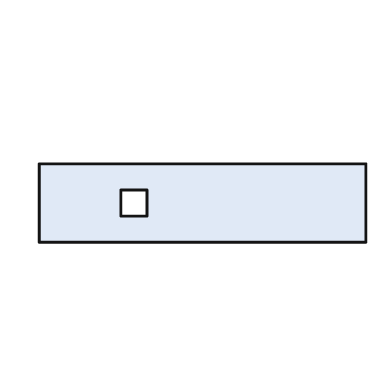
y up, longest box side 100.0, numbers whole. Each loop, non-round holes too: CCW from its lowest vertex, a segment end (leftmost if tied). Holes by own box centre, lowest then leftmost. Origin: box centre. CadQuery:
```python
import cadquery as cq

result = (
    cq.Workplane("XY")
    .moveTo(-50.0, -12.0)
    .lineTo(50.0, -12.0)
    .lineTo(50.0, 12.0)
    .lineTo(-50.0, 12.0)
    .close()
    .moveTo(-25.0, -4.0)
    .lineTo(-17.0, -4.0)
    .lineTo(-17.0, 4.0)
    .lineTo(-25.0, 4.0)
    .close()
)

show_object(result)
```